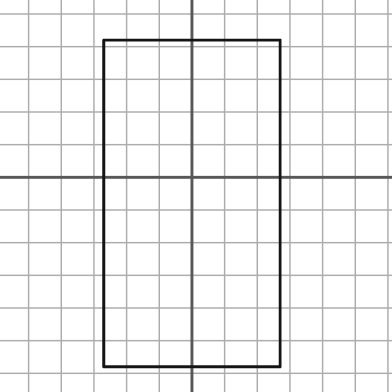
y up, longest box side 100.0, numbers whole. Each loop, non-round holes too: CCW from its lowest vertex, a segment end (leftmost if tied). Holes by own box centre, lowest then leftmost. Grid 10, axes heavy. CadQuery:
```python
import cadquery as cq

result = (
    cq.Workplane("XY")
    .moveTo(-27.0, -58.0)
    .lineTo(27.0, -58.0)
    .lineTo(27.0, 42.0)
    .lineTo(-27.0, 42.0)
    .close()
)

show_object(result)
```